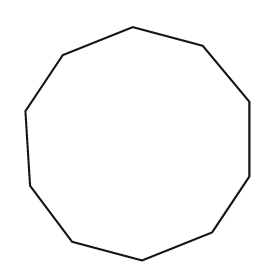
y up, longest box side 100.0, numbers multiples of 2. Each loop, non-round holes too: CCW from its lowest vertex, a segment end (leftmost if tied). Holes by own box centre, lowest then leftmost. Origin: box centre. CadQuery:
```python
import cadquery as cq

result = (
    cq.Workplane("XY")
    .moveTo(2.0, -50.0)
    .lineTo(32.0, -38.0)
    .lineTo(48.0, -14.0)
    .lineTo(48.0, 18.0)
    .lineTo(28.0, 42.0)
    .lineTo(-2.0, 50.0)
    .lineTo(-32.0, 38.0)
    .lineTo(-48.0, 14.0)
    .lineTo(-46.0, -18.0)
    .lineTo(-28.0, -42.0)
    .close()
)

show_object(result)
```